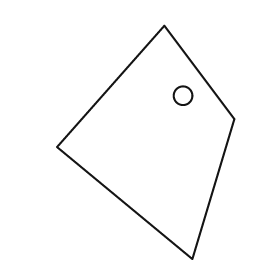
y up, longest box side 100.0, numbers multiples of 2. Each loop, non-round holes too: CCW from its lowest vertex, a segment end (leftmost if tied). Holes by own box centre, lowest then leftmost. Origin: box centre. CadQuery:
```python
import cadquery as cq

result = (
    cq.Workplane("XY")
    .moveTo(20.0, -50.0)
    .lineTo(38.0, 10.0)
    .lineTo(8.0, 50.0)
    .lineTo(-38.0, -2.0)
    .close()
    .moveTo(16.0, 20.0)
    .circle(4.0)
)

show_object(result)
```